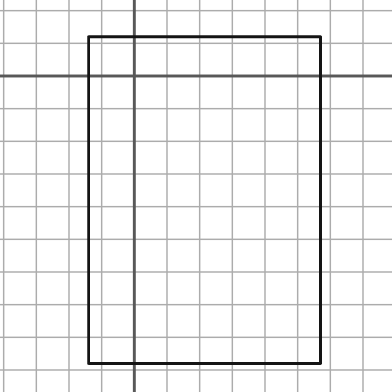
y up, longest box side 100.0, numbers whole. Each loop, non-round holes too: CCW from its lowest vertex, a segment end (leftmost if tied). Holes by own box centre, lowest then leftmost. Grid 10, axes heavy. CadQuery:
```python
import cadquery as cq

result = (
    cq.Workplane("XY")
    .moveTo(-14.0, -88.0)
    .lineTo(57.0, -88.0)
    .lineTo(57.0, 12.0)
    .lineTo(-14.0, 12.0)
    .close()
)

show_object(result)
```